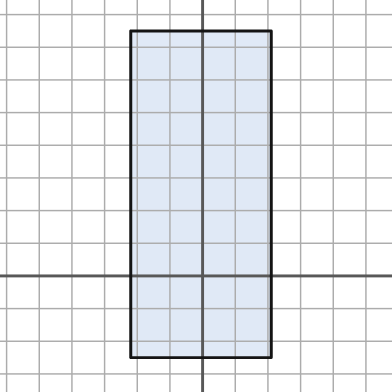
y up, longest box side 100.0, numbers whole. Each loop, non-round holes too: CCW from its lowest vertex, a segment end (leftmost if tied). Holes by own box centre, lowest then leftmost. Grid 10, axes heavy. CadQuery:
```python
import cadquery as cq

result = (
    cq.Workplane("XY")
    .moveTo(-22.0, -25.0)
    .lineTo(21.0, -25.0)
    .lineTo(21.0, 75.0)
    .lineTo(-22.0, 75.0)
    .close()
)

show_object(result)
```